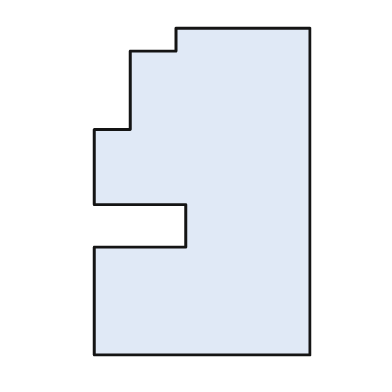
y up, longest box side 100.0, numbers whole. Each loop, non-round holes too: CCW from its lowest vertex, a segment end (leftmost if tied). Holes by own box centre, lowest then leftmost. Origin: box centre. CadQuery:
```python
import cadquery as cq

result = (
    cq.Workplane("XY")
    .moveTo(-33.0, -50.0)
    .lineTo(33.0, -50.0)
    .lineTo(33.0, 50.0)
    .lineTo(-8.0, 50.0)
    .lineTo(-8.0, 43.0)
    .lineTo(-22.0, 43.0)
    .lineTo(-22.0, 19.0)
    .lineTo(-33.0, 19.0)
    .lineTo(-33.0, -4.0)
    .lineTo(-5.0, -4.0)
    .lineTo(-5.0, -17.0)
    .lineTo(-33.0, -17.0)
    .close()
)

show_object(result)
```